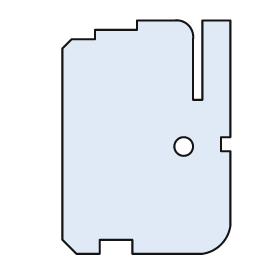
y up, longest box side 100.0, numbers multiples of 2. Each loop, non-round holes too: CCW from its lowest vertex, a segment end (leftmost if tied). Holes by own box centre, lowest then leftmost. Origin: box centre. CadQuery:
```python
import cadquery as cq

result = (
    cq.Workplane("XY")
    .moveTo(-30.0, -50.0)
    .lineTo(-20.0, -50.0)
    .lineTo(-20.0, -44.0)
    .lineTo(-6.0, -44.0)
    .lineTo(-6.0, -50.0)
    .lineTo(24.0, -50.0)
    .threePointArc((32.0, -46.0), (36.0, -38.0))
    .lineTo(36.0, -6.0)
    .lineTo(32.0, -6.0)
    .lineTo(32.0, 0.0)
    .lineTo(36.0, 0.0)
    .lineTo(36.0, 50.0)
    .lineTo(24.0, 50.0)
    .lineTo(24.0, 16.0)
    .lineTo(20.0, 16.0)
    .lineTo(20.0, 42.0)
    .threePointArc((18.0, 48.0), (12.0, 50.0))
    .lineTo(-4.0, 50.0)
    .lineTo(-4.0, 46.0)
    .lineTo(-22.0, 46.0)
    .lineTo(-22.0, 42.0)
    .lineTo(-32.0, 42.0)
    .lineTo(-36.0, 38.0)
    .lineTo(-36.0, -44.0)
    .close()
    .moveTo(16.0, -4.0)
    .circle(4.0)
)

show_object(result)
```